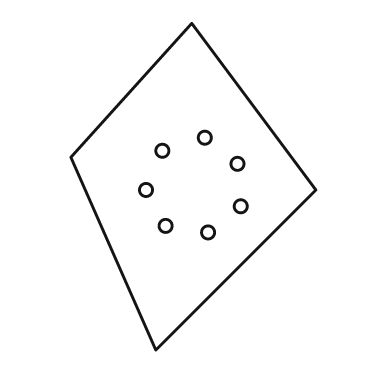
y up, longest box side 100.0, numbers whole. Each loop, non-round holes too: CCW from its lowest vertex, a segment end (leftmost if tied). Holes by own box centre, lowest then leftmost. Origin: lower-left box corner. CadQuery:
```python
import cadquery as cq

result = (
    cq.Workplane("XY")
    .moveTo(26.0, 0.0)
    .lineTo(75.0, 49.0)
    .lineTo(37.0, 100.0)
    .lineTo(0.0, 59.0)
    .close()
    .moveTo(42.0, 36.0)
    .circle(2.0)
    .moveTo(29.0, 38.0)
    .circle(2.0)
    .moveTo(52.0, 44.0)
    .circle(2.0)
    .moveTo(23.0, 49.0)
    .circle(2.0)
    .moveTo(51.0, 57.0)
    .circle(2.0)
    .moveTo(28.0, 61.0)
    .circle(2.0)
    .moveTo(41.0, 65.0)
    .circle(2.0)
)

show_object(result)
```